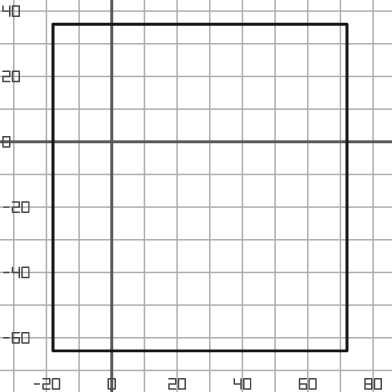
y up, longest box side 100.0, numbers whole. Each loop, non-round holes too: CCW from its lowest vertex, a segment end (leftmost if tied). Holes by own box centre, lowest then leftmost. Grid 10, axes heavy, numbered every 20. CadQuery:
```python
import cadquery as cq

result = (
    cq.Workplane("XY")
    .moveTo(-18.0, -64.0)
    .lineTo(72.0, -64.0)
    .lineTo(72.0, 36.0)
    .lineTo(-18.0, 36.0)
    .close()
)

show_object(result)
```